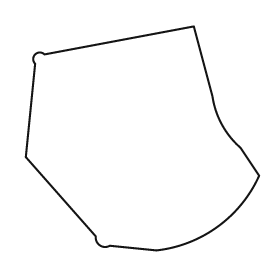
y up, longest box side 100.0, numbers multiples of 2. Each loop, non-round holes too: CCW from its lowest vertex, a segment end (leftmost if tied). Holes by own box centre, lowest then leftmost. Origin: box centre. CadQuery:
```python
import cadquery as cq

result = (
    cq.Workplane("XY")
    .moveTo(6.0, -48.0)
    .threePointArc((32.0, -38.0), (50.0, -16.0))
    .lineTo(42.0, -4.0)
    .threePointArc((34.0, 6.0), (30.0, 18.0))
    .lineTo(22.0, 48.0)
    .lineTo(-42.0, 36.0)
    .threePointArc((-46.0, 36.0), (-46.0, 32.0))
    .lineTo(-50.0, -8.0)
    .lineTo(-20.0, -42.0)
    .threePointArc((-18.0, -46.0), (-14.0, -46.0))
    .close()
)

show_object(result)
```